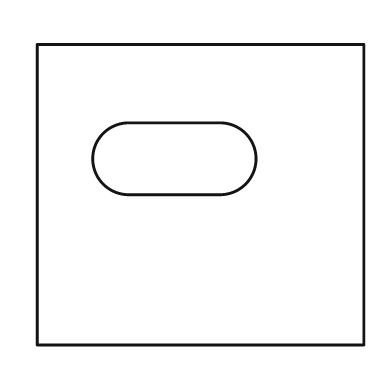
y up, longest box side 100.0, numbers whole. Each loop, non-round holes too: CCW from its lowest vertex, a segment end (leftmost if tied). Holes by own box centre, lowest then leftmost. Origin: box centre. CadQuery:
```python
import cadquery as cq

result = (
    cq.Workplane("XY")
    .moveTo(-50.0, -46.0)
    .lineTo(50.0, -46.0)
    .lineTo(50.0, 46.0)
    .lineTo(-50.0, 46.0)
    .close()
    .moveTo(-22.0, 0.0)
    .lineTo(6.0, 0.0)
    .threePointArc((17.0, 11.0), (6.0, 22.0))
    .lineTo(-22.0, 22.0)
    .threePointArc((-33.0, 11.0), (-22.0, 0.0))
    .close()
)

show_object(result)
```